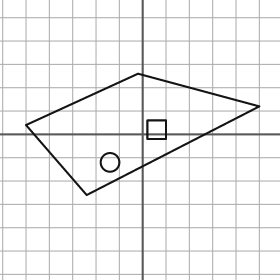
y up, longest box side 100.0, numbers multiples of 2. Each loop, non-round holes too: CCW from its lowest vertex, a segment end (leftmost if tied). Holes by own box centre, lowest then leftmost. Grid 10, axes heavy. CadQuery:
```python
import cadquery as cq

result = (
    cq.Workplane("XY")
    .moveTo(-24.0, -26.0)
    .lineTo(50.0, 12.0)
    .lineTo(-2.0, 26.0)
    .lineTo(-50.0, 4.0)
    .close()
    .moveTo(-14.0, -12.0)
    .circle(4.0)
    .moveTo(2.0, -2.0)
    .lineTo(10.0, -2.0)
    .lineTo(10.0, 6.0)
    .lineTo(2.0, 6.0)
    .close()
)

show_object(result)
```